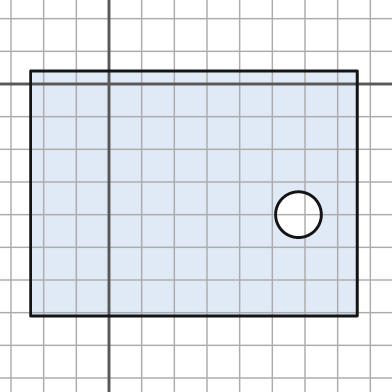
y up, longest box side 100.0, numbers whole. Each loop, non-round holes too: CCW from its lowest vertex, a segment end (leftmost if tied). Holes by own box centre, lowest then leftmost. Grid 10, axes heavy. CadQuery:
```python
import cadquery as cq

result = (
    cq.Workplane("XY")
    .moveTo(-24.0, -71.0)
    .lineTo(76.0, -71.0)
    .lineTo(76.0, 4.0)
    .lineTo(-24.0, 4.0)
    .close()
    .moveTo(58.0, -40.0)
    .circle(7.0)
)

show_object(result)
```